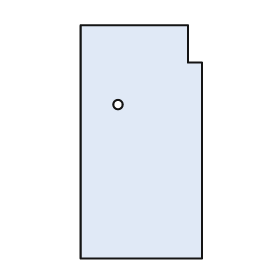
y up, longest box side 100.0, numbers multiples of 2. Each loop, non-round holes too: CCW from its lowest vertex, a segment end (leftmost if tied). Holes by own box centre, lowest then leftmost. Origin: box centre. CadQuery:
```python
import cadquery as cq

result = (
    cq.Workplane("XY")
    .moveTo(-26.0, -50.0)
    .lineTo(26.0, -50.0)
    .lineTo(26.0, 34.0)
    .lineTo(20.0, 34.0)
    .lineTo(20.0, 50.0)
    .lineTo(-26.0, 50.0)
    .close()
    .moveTo(-10.0, 16.0)
    .circle(2.0)
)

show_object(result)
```